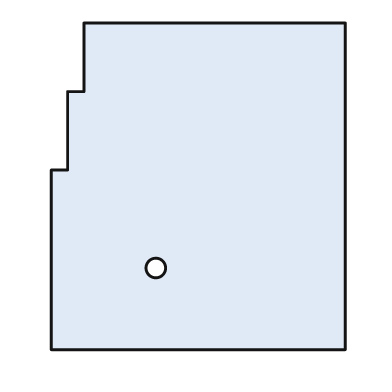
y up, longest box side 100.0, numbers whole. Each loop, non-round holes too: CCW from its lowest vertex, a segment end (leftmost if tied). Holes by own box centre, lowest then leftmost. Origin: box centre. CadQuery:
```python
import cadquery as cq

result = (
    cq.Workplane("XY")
    .moveTo(-45.0, -50.0)
    .lineTo(45.0, -50.0)
    .lineTo(45.0, 50.0)
    .lineTo(-35.0, 50.0)
    .lineTo(-35.0, 29.0)
    .lineTo(-40.0, 29.0)
    .lineTo(-40.0, 5.0)
    .lineTo(-45.0, 5.0)
    .close()
    .moveTo(-13.0, -25.0)
    .circle(3.0)
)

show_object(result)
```